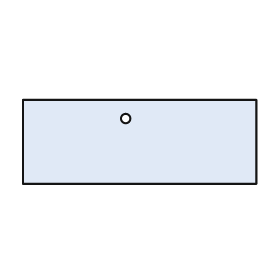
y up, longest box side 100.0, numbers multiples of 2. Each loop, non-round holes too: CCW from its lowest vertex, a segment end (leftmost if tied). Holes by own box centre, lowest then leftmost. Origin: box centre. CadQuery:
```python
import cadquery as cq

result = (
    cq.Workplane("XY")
    .moveTo(-50.0, -18.0)
    .lineTo(50.0, -18.0)
    .lineTo(50.0, 18.0)
    .lineTo(-50.0, 18.0)
    .close()
    .moveTo(-6.0, 10.0)
    .circle(2.0)
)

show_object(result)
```